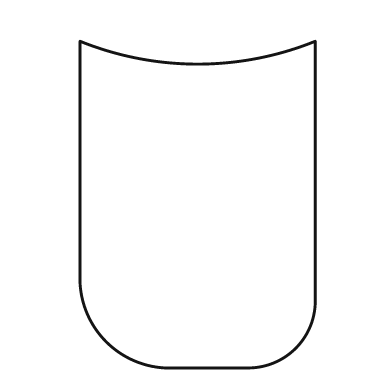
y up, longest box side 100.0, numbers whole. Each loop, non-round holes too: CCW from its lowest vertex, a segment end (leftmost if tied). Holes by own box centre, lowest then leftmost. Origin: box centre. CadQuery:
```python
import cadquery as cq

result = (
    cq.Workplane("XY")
    .moveTo(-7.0, -50.0)
    .lineTo(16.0, -50.0)
    .threePointArc((30.0, -44.0), (36.0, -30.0))
    .lineTo(36.0, 50.0)
    .threePointArc((0.0, 43.0), (-36.0, 50.0))
    .lineTo(-36.0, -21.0)
    .threePointArc((-28.0, -42.0), (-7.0, -50.0))
    .close()
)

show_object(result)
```